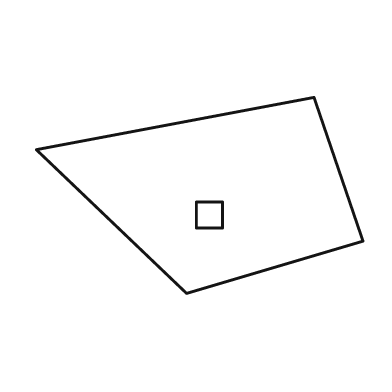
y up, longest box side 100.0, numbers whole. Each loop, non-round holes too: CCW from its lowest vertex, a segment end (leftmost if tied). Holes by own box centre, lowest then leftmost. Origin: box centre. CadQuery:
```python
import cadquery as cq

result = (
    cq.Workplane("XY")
    .moveTo(-4.0, -30.0)
    .lineTo(50.0, -14.0)
    .lineTo(35.0, 30.0)
    .lineTo(-50.0, 14.0)
    .close()
    .moveTo(-1.0, -10.0)
    .lineTo(7.0, -10.0)
    .lineTo(7.0, -2.0)
    .lineTo(-1.0, -2.0)
    .close()
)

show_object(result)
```